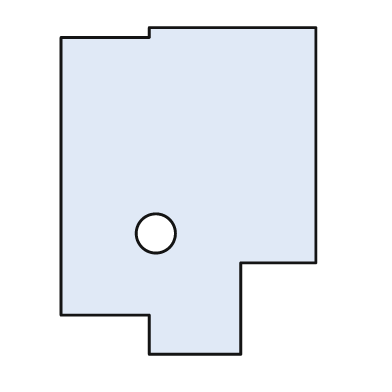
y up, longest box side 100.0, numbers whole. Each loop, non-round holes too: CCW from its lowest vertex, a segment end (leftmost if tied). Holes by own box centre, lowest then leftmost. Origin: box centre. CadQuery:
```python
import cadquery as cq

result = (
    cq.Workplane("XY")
    .moveTo(-12.0, -50.0)
    .lineTo(16.0, -50.0)
    .lineTo(16.0, -22.0)
    .lineTo(39.0, -22.0)
    .lineTo(39.0, 50.0)
    .lineTo(-12.0, 50.0)
    .lineTo(-12.0, 47.0)
    .lineTo(-39.0, 47.0)
    .lineTo(-39.0, -38.0)
    .lineTo(-12.0, -38.0)
    .close()
    .moveTo(-10.0, -13.0)
    .circle(6.0)
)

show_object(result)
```